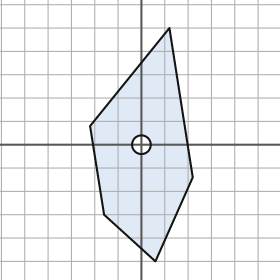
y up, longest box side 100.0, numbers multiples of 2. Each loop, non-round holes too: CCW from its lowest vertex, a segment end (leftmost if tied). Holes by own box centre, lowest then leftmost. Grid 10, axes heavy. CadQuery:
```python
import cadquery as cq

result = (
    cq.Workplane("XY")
    .moveTo(6.0, -50.0)
    .lineTo(22.0, -14.0)
    .lineTo(12.0, 50.0)
    .lineTo(-22.0, 8.0)
    .lineTo(-16.0, -30.0)
    .close()
    .moveTo(0.0, 0.0)
    .circle(4.0)
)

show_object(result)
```